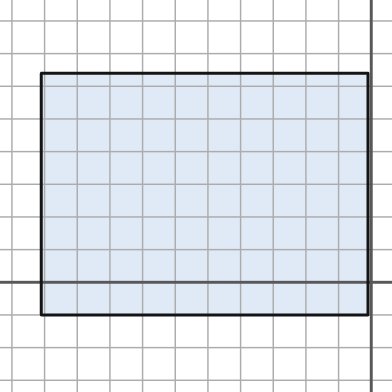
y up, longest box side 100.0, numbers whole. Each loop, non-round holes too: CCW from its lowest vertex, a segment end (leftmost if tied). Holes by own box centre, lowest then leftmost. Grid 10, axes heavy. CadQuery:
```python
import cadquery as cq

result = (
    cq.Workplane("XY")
    .moveTo(-101.0, -10.0)
    .lineTo(-1.0, -10.0)
    .lineTo(-1.0, 64.0)
    .lineTo(-101.0, 64.0)
    .close()
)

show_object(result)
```